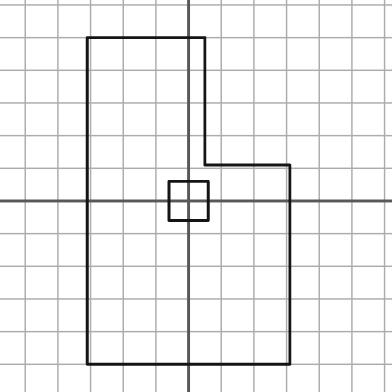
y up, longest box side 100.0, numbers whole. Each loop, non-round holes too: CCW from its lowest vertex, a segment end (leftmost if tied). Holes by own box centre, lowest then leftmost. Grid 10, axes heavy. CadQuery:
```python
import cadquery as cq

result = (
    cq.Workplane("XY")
    .moveTo(-31.0, -50.0)
    .lineTo(31.0, -50.0)
    .lineTo(31.0, 11.0)
    .lineTo(5.0, 11.0)
    .lineTo(5.0, 50.0)
    .lineTo(-31.0, 50.0)
    .close()
    .moveTo(-6.0, -6.0)
    .lineTo(6.0, -6.0)
    .lineTo(6.0, 6.0)
    .lineTo(-6.0, 6.0)
    .close()
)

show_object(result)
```